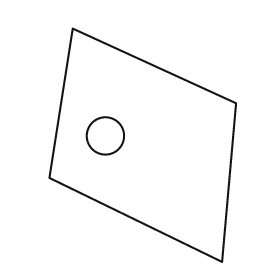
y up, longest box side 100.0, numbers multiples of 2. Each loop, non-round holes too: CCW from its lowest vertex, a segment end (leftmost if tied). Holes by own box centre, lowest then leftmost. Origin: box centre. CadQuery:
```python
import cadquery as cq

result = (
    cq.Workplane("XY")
    .moveTo(34.0, -50.0)
    .lineTo(40.0, 18.0)
    .lineTo(-30.0, 50.0)
    .lineTo(-40.0, -14.0)
    .close()
    .moveTo(-16.0, 4.0)
    .circle(8.0)
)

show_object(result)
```